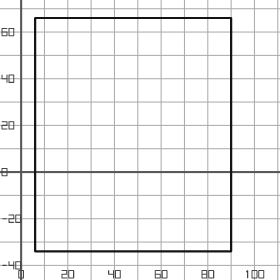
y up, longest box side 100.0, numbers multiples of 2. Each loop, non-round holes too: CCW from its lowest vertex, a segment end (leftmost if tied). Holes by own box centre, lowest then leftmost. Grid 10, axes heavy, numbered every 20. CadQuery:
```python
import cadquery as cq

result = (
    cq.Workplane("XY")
    .moveTo(6.0, -34.0)
    .lineTo(90.0, -34.0)
    .lineTo(90.0, 66.0)
    .lineTo(6.0, 66.0)
    .close()
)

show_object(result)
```